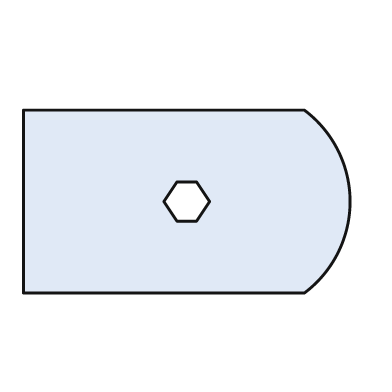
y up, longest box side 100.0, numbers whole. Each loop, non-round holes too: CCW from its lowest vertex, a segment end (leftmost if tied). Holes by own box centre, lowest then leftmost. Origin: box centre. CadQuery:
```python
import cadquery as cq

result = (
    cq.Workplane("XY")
    .moveTo(-50.0, -28.0)
    .lineTo(36.0, -28.0)
    .threePointArc((50.0, 0.0), (36.0, 28.0))
    .lineTo(-50.0, 28.0)
    .close()
    .moveTo(-3.0, -6.0)
    .lineTo(3.0, -6.0)
    .lineTo(7.0, 0.0)
    .lineTo(3.0, 6.0)
    .lineTo(-3.0, 6.0)
    .lineTo(-7.0, 0.0)
    .close()
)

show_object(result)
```